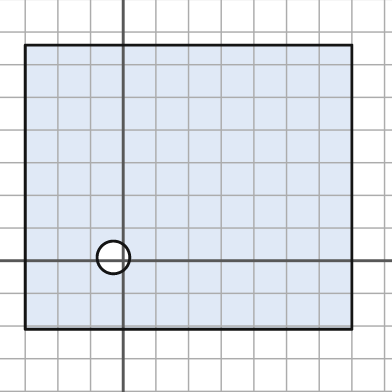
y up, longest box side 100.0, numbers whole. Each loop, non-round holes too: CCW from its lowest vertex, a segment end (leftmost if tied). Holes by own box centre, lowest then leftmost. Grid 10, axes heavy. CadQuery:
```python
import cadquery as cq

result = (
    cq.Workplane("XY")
    .moveTo(-30.0, -21.0)
    .lineTo(70.0, -21.0)
    .lineTo(70.0, 66.0)
    .lineTo(-30.0, 66.0)
    .close()
    .moveTo(-3.0, 1.0)
    .circle(5.0)
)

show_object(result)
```